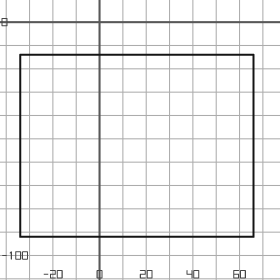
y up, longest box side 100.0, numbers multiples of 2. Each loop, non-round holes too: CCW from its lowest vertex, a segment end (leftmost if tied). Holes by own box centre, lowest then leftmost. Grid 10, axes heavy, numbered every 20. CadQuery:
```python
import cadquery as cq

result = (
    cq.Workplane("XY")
    .moveTo(-34.0, -92.0)
    .lineTo(66.0, -92.0)
    .lineTo(66.0, -14.0)
    .lineTo(-34.0, -14.0)
    .close()
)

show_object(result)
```